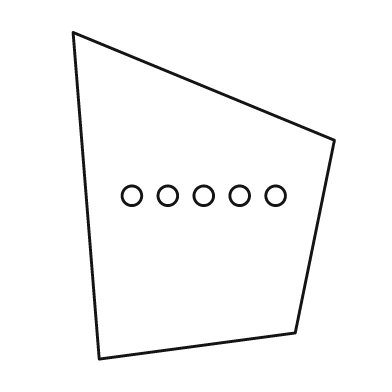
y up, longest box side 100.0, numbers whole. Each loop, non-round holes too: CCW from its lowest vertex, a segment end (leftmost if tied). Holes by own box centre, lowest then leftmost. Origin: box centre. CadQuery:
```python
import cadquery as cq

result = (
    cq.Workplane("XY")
    .moveTo(-32.0, -50.0)
    .lineTo(28.0, -42.0)
    .lineTo(40.0, 17.0)
    .lineTo(-40.0, 50.0)
    .close()
    .moveTo(-22.0, 0.0)
    .circle(3.0)
    .moveTo(-11.0, 0.0)
    .circle(3.0)
    .moveTo(0.0, 0.0)
    .circle(3.0)
    .moveTo(11.0, 0.0)
    .circle(3.0)
    .moveTo(22.0, 0.0)
    .circle(3.0)
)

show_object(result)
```